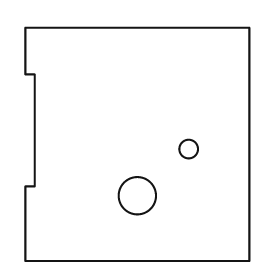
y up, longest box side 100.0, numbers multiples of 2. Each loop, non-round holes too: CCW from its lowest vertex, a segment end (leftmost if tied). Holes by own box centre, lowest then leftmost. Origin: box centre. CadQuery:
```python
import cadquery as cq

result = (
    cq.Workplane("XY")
    .moveTo(-48.0, -50.0)
    .lineTo(48.0, -50.0)
    .lineTo(48.0, 50.0)
    .lineTo(-48.0, 50.0)
    .lineTo(-48.0, 30.0)
    .lineTo(-44.0, 30.0)
    .lineTo(-44.0, -18.0)
    .lineTo(-48.0, -18.0)
    .close()
    .moveTo(0.0, -22.0)
    .circle(8.0)
    .moveTo(22.0, -2.0)
    .circle(4.0)
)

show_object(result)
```